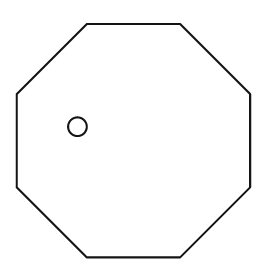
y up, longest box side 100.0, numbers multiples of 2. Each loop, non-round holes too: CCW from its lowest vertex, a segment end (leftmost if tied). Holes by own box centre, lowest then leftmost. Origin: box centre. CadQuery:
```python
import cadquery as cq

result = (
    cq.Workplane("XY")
    .moveTo(-20.0, -50.0)
    .lineTo(20.0, -50.0)
    .lineTo(50.0, -20.0)
    .lineTo(50.0, 20.0)
    .lineTo(20.0, 50.0)
    .lineTo(-20.0, 50.0)
    .lineTo(-50.0, 20.0)
    .lineTo(-50.0, -20.0)
    .close()
    .moveTo(-24.0, 6.0)
    .circle(4.0)
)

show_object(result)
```